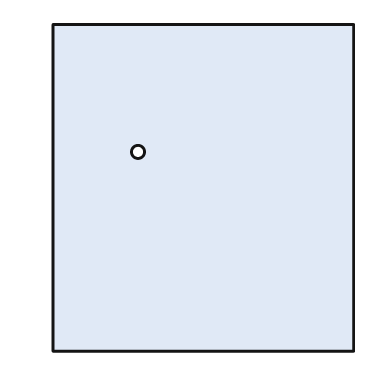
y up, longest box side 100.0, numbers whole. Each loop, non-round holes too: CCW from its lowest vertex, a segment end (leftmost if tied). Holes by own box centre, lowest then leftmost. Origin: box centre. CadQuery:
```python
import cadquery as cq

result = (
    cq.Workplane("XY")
    .moveTo(-46.0, -50.0)
    .lineTo(46.0, -50.0)
    .lineTo(46.0, 50.0)
    .lineTo(-46.0, 50.0)
    .close()
    .moveTo(-20.0, 11.0)
    .circle(2.0)
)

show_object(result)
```